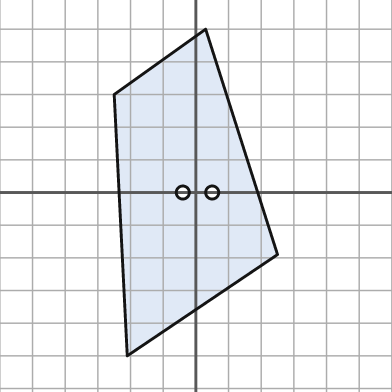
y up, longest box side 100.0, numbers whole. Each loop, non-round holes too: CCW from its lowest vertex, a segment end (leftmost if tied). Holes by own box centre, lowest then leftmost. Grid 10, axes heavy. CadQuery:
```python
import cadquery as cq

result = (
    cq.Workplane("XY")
    .moveTo(-21.0, -50.0)
    .lineTo(25.0, -19.0)
    .lineTo(3.0, 50.0)
    .lineTo(-25.0, 30.0)
    .close()
    .moveTo(-4.0, 0.0)
    .circle(2.0)
    .moveTo(5.0, 0.0)
    .circle(2.0)
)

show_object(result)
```